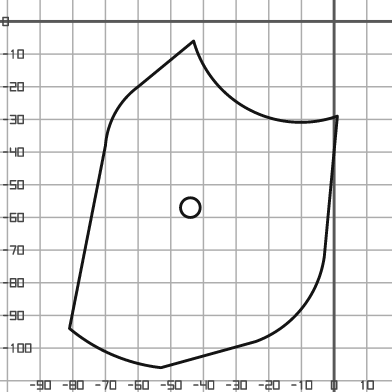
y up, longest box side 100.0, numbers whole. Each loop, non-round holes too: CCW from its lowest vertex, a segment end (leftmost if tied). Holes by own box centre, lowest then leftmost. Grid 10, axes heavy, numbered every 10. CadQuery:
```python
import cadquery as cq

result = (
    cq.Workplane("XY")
    .moveTo(-53.0, -106.0)
    .lineTo(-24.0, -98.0)
    .threePointArc((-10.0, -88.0), (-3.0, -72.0))
    .lineTo(1.0, -29.0)
    .threePointArc((-26.0, -27.0), (-43.0, -6.0))
    .lineTo(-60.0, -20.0)
    .threePointArc((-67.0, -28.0), (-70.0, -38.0))
    .lineTo(-81.0, -94.0)
    .threePointArc((-68.0, -102.0), (-53.0, -106.0))
    .close()
    .moveTo(-44.0, -57.0)
    .circle(3.0)
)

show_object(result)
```